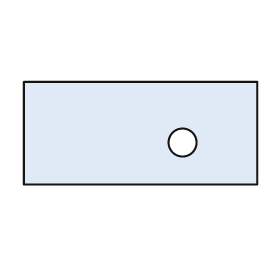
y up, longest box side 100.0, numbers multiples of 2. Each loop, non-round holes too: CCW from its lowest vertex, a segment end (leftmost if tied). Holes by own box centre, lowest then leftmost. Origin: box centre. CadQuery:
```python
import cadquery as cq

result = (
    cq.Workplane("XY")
    .moveTo(-50.0, -22.0)
    .lineTo(50.0, -22.0)
    .lineTo(50.0, 22.0)
    .lineTo(-50.0, 22.0)
    .close()
    .moveTo(18.0, -4.0)
    .circle(6.0)
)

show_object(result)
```